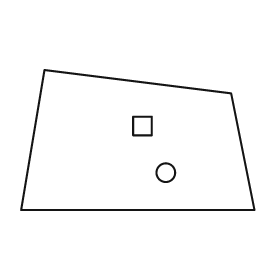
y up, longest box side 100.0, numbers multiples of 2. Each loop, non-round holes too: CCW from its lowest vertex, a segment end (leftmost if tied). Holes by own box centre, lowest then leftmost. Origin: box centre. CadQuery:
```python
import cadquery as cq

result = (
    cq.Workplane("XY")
    .moveTo(-50.0, -30.0)
    .lineTo(50.0, -30.0)
    .lineTo(40.0, 20.0)
    .lineTo(-40.0, 30.0)
    .close()
    .moveTo(12.0, -14.0)
    .circle(4.0)
    .moveTo(-2.0, 2.0)
    .lineTo(6.0, 2.0)
    .lineTo(6.0, 10.0)
    .lineTo(-2.0, 10.0)
    .close()
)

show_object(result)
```